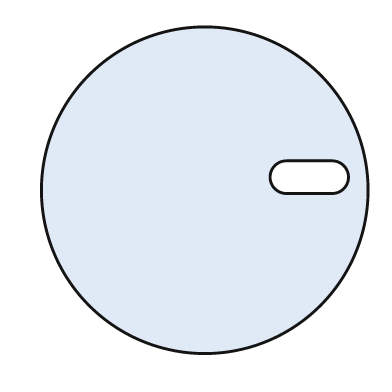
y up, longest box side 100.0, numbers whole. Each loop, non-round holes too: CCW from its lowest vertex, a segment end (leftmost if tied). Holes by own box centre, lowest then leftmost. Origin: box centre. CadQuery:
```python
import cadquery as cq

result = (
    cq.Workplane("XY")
    .moveTo(0.0, 0.0)
    .circle(50.0)
    .moveTo(25.0, -1.0)
    .lineTo(39.0, -1.0)
    .threePointArc((44.0, 4.0), (39.0, 9.0))
    .lineTo(25.0, 9.0)
    .threePointArc((20.0, 4.0), (25.0, -1.0))
    .close()
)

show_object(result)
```